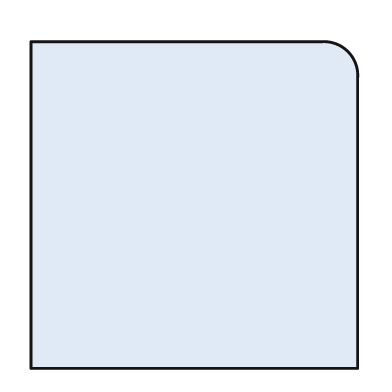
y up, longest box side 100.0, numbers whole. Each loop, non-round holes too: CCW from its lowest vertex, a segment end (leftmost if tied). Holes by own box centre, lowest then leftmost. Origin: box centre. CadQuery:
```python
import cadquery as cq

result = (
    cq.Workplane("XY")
    .moveTo(-50.0, -50.0)
    .lineTo(50.0, -50.0)
    .lineTo(50.0, 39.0)
    .threePointArc((47.0, 47.0), (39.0, 50.0))
    .lineTo(-50.0, 50.0)
    .close()
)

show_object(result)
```